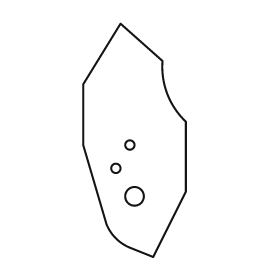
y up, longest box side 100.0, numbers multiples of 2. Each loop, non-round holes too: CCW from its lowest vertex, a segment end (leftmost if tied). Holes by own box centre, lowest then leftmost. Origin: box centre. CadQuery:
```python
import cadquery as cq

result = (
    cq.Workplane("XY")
    .moveTo(8.0, -50.0)
    .lineTo(22.0, -22.0)
    .lineTo(22.0, 8.0)
    .threePointArc((14.0, 20.0), (12.0, 34.0))
    .lineTo(-6.0, 50.0)
    .lineTo(-22.0, 24.0)
    .lineTo(-22.0, -2.0)
    .lineTo(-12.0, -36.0)
    .threePointArc((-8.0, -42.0), (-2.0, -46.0))
    .close()
    .moveTo(0.0, -24.0)
    .circle(4.0)
    .moveTo(-8.0, -12.0)
    .circle(2.0)
    .moveTo(-2.0, -2.0)
    .circle(2.0)
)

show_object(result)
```